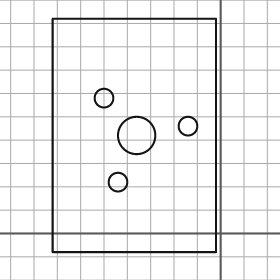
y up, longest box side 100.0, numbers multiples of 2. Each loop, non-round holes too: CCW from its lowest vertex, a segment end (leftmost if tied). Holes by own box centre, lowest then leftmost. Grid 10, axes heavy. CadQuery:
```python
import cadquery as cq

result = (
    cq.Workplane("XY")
    .moveTo(-72.0, -8.0)
    .lineTo(-2.0, -8.0)
    .lineTo(-2.0, 92.0)
    .lineTo(-72.0, 92.0)
    .close()
    .moveTo(-44.0, 22.0)
    .circle(4.0)
    .moveTo(-36.0, 42.0)
    .circle(8.0)
    .moveTo(-14.0, 46.0)
    .circle(4.0)
    .moveTo(-50.0, 58.0)
    .circle(4.0)
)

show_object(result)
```